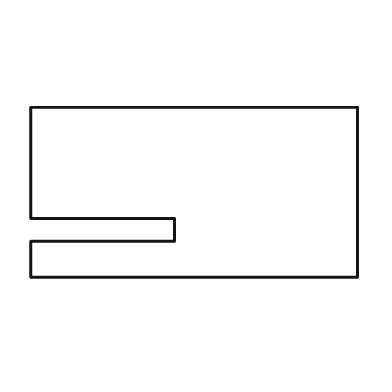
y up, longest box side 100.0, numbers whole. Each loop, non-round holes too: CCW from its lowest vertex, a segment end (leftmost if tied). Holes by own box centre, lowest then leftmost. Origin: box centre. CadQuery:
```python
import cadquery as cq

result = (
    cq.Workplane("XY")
    .moveTo(-50.0, -26.0)
    .lineTo(50.0, -26.0)
    .lineTo(50.0, 26.0)
    .lineTo(-50.0, 26.0)
    .lineTo(-50.0, -8.0)
    .lineTo(-6.0, -8.0)
    .lineTo(-6.0, -15.0)
    .lineTo(-50.0, -15.0)
    .close()
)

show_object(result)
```